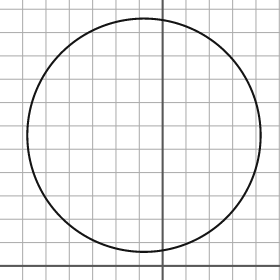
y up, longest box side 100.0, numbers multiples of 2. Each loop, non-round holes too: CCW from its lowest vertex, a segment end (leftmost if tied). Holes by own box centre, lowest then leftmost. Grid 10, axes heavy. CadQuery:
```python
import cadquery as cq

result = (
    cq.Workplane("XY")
    .moveTo(-8.0, 56.0)
    .circle(50.0)
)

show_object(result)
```